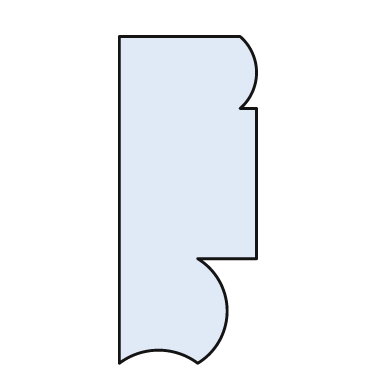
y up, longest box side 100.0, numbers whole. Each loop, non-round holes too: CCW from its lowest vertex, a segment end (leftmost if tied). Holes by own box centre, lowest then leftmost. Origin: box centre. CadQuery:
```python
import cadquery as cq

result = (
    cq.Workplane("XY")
    .moveTo(-21.0, -50.0)
    .threePointArc((-9.0, -46.0), (3.0, -50.0))
    .threePointArc((12.0, -34.0), (3.0, -18.0))
    .lineTo(21.0, -18.0)
    .lineTo(21.0, 28.0)
    .lineTo(16.0, 28.0)
    .threePointArc((21.0, 39.0), (16.0, 50.0))
    .lineTo(-21.0, 50.0)
    .close()
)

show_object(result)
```